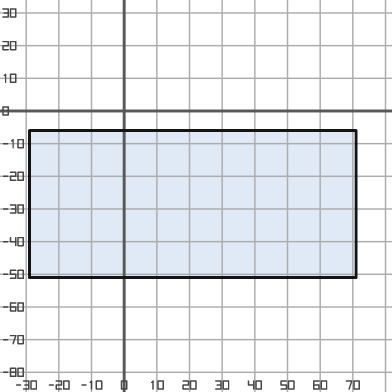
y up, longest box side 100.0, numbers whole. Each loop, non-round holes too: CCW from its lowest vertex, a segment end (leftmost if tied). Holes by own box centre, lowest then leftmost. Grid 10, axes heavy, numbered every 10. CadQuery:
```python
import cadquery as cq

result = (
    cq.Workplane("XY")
    .moveTo(-29.0, -51.0)
    .lineTo(71.0, -51.0)
    .lineTo(71.0, -6.0)
    .lineTo(-29.0, -6.0)
    .close()
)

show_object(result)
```